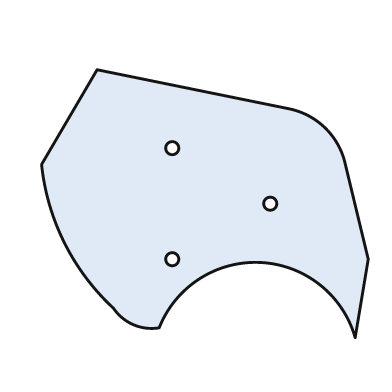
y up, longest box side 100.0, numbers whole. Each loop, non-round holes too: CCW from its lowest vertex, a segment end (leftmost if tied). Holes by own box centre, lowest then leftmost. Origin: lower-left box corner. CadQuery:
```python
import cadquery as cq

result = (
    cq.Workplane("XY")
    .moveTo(96.0, 0.0)
    .lineTo(100.0, 24.0)
    .lineTo(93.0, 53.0)
    .threePointArc((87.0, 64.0), (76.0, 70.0))
    .lineTo(17.0, 82.0)
    .lineTo(0.0, 53.0)
    .threePointArc((7.0, 29.0), (22.0, 9.0))
    .threePointArc((28.0, 4.0), (36.0, 3.0))
    .threePointArc((67.0, 23.0), (96.0, 0.0))
    .close()
    .moveTo(40.0, 24.0)
    .circle(2.0)
    .moveTo(70.0, 41.0)
    .circle(2.0)
    .moveTo(40.0, 58.0)
    .circle(2.0)
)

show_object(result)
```